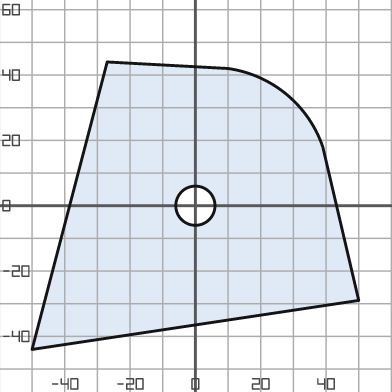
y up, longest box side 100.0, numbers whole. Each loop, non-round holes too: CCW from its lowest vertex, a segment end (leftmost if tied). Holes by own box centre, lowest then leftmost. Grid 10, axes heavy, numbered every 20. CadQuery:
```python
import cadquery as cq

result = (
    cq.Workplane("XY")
    .moveTo(-50.0, -44.0)
    .lineTo(50.0, -29.0)
    .lineTo(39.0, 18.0)
    .threePointArc((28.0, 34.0), (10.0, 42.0))
    .lineTo(-27.0, 44.0)
    .close()
    .moveTo(0.0, 0.0)
    .circle(6.0)
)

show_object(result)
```